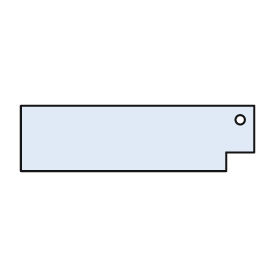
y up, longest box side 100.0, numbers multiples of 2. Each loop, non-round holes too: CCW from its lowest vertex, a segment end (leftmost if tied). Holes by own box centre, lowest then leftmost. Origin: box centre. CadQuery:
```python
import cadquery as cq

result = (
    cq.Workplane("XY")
    .moveTo(-50.0, -14.0)
    .lineTo(38.0, -14.0)
    .lineTo(38.0, -6.0)
    .lineTo(50.0, -6.0)
    .lineTo(50.0, 14.0)
    .lineTo(-50.0, 14.0)
    .close()
    .moveTo(44.0, 8.0)
    .circle(2.0)
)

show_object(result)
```